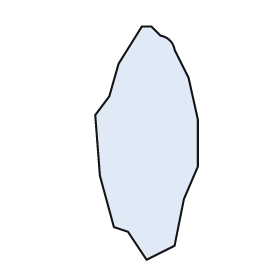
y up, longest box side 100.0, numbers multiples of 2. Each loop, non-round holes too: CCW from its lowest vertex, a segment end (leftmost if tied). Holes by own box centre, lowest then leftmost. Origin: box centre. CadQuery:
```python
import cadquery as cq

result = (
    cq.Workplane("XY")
    .moveTo(0.0, -50.0)
    .lineTo(12.0, -44.0)
    .lineTo(16.0, -24.0)
    .lineTo(22.0, -10.0)
    .lineTo(22.0, 10.0)
    .lineTo(18.0, 28.0)
    .lineTo(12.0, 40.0)
    .threePointArc((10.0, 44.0), (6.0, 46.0))
    .lineTo(2.0, 50.0)
    .lineTo(-2.0, 50.0)
    .lineTo(-12.0, 34.0)
    .lineTo(-16.0, 20.0)
    .lineTo(-22.0, 12.0)
    .lineTo(-20.0, -14.0)
    .lineTo(-14.0, -36.0)
    .lineTo(-8.0, -38.0)
    .close()
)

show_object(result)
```